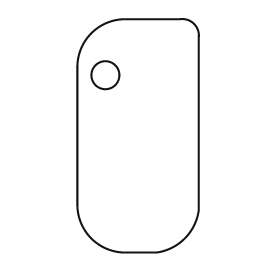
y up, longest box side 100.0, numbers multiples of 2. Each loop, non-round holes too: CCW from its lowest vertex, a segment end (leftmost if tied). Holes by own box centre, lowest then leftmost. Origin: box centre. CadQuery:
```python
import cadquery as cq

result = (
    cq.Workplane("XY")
    .moveTo(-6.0, -50.0)
    .lineTo(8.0, -50.0)
    .threePointArc((20.0, -44.0), (26.0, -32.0))
    .lineTo(26.0, 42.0)
    .threePointArc((24.0, 48.0), (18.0, 50.0))
    .lineTo(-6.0, 50.0)
    .threePointArc((-20.0, 44.0), (-26.0, 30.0))
    .lineTo(-26.0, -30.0)
    .threePointArc((-20.0, -44.0), (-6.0, -50.0))
    .close()
    .moveTo(-14.0, 26.0)
    .circle(6.0)
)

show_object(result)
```